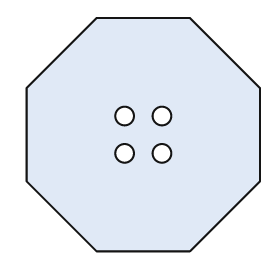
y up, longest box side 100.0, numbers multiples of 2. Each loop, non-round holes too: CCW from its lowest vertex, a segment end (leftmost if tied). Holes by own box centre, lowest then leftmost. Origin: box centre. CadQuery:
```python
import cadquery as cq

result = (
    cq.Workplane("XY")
    .moveTo(-20.0, -50.0)
    .lineTo(20.0, -50.0)
    .lineTo(50.0, -20.0)
    .lineTo(50.0, 20.0)
    .lineTo(20.0, 50.0)
    .lineTo(-20.0, 50.0)
    .lineTo(-50.0, 20.0)
    .lineTo(-50.0, -20.0)
    .close()
    .moveTo(-8.0, -8.0)
    .circle(4.0)
    .moveTo(8.0, -8.0)
    .circle(4.0)
    .moveTo(-8.0, 8.0)
    .circle(4.0)
    .moveTo(8.0, 8.0)
    .circle(4.0)
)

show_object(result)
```